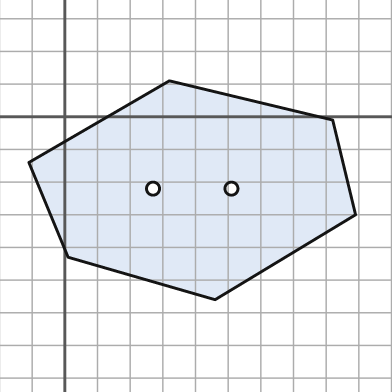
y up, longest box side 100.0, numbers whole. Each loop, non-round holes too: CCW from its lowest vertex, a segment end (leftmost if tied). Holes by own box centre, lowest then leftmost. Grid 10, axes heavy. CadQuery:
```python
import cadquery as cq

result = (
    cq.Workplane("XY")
    .moveTo(46.0, -56.0)
    .lineTo(89.0, -30.0)
    .lineTo(82.0, -1.0)
    .lineTo(32.0, 11.0)
    .lineTo(-11.0, -14.0)
    .lineTo(1.0, -43.0)
    .close()
    .moveTo(27.0, -22.0)
    .circle(2.0)
    .moveTo(51.0, -22.0)
    .circle(2.0)
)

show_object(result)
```